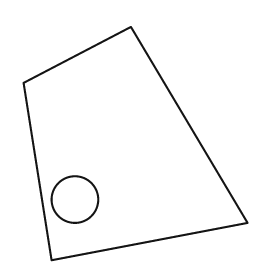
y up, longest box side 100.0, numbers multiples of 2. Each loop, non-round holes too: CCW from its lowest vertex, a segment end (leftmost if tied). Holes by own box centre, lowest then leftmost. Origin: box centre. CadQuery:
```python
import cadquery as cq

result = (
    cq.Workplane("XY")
    .moveTo(-36.0, -50.0)
    .lineTo(48.0, -34.0)
    .lineTo(-2.0, 50.0)
    .lineTo(-48.0, 26.0)
    .close()
    .moveTo(-26.0, -24.0)
    .circle(10.0)
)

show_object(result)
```